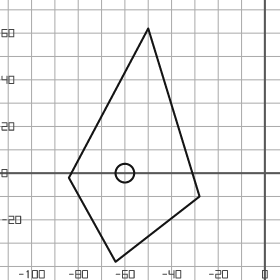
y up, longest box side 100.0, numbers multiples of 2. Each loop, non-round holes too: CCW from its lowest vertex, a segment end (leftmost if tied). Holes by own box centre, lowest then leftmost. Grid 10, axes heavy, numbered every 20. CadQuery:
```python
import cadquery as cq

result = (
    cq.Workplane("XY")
    .moveTo(-64.0, -38.0)
    .lineTo(-28.0, -10.0)
    .lineTo(-50.0, 62.0)
    .lineTo(-84.0, -2.0)
    .close()
    .moveTo(-60.0, 0.0)
    .circle(4.0)
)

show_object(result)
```